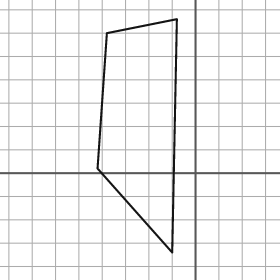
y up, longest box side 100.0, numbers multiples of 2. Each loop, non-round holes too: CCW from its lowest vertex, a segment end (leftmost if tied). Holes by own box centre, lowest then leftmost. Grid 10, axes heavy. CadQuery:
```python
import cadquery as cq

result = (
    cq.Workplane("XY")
    .moveTo(-10.0, -34.0)
    .lineTo(-8.0, 66.0)
    .lineTo(-38.0, 60.0)
    .lineTo(-42.0, 2.0)
    .close()
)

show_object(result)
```